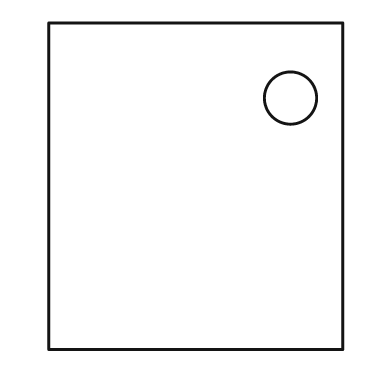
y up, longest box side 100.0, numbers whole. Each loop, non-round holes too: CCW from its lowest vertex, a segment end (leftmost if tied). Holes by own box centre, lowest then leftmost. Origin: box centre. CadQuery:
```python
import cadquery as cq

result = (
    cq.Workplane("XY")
    .moveTo(-45.0, -50.0)
    .lineTo(45.0, -50.0)
    .lineTo(45.0, 50.0)
    .lineTo(-45.0, 50.0)
    .close()
    .moveTo(29.0, 27.0)
    .circle(8.0)
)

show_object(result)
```